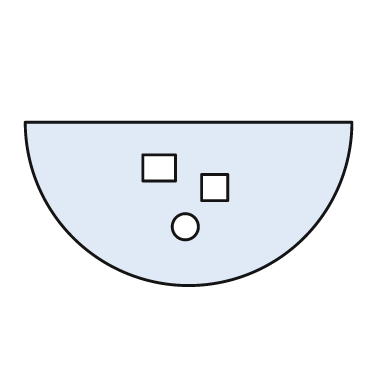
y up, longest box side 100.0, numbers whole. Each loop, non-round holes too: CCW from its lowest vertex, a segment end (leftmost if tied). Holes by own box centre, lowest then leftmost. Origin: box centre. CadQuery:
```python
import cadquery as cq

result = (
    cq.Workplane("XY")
    .moveTo(-50.0, 25.0)
    .threePointArc((0.0, -25.0), (50.0, 25.0))
    .close()
    .moveTo(-1.0, -7.0)
    .circle(4.0)
    .moveTo(4.0, 1.0)
    .lineTo(12.0, 1.0)
    .lineTo(12.0, 9.0)
    .lineTo(4.0, 9.0)
    .close()
    .moveTo(-14.0, 7.0)
    .lineTo(-4.0, 7.0)
    .lineTo(-4.0, 15.0)
    .lineTo(-14.0, 15.0)
    .close()
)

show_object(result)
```